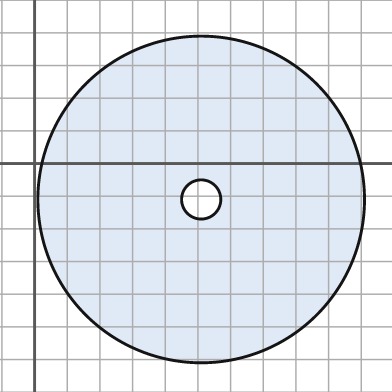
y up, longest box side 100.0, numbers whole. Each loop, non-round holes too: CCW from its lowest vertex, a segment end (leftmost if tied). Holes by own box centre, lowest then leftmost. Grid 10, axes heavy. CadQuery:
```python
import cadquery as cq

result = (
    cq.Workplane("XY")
    .moveTo(51.0, -11.0)
    .circle(50.0)
    .moveTo(51.0, -11.0)
    .circle(6.0)
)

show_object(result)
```